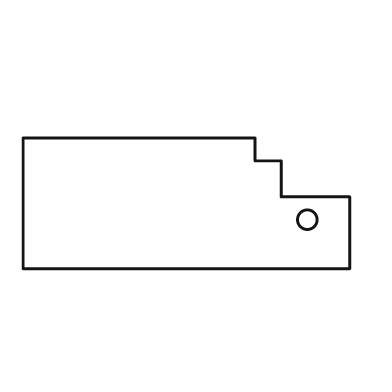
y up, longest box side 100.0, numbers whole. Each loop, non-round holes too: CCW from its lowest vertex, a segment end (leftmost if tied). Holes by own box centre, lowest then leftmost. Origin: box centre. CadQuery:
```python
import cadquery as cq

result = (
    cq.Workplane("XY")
    .moveTo(-50.0, -20.0)
    .lineTo(50.0, -20.0)
    .lineTo(50.0, 2.0)
    .lineTo(29.0, 2.0)
    .lineTo(29.0, 13.0)
    .lineTo(21.0, 13.0)
    .lineTo(21.0, 20.0)
    .lineTo(-50.0, 20.0)
    .close()
    .moveTo(37.0, -5.0)
    .circle(3.0)
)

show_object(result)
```